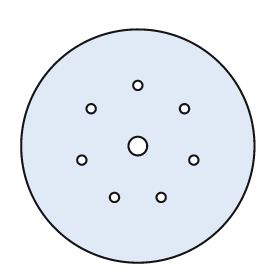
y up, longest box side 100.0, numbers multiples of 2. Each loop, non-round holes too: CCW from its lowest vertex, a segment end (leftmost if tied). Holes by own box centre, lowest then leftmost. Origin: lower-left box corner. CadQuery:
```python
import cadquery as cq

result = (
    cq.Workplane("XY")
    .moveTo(50.0, 50.0)
    .circle(50.0)
    .moveTo(40.0, 28.0)
    .circle(2.0)
    .moveTo(60.0, 28.0)
    .circle(2.0)
    .moveTo(26.0, 44.0)
    .circle(2.0)
    .moveTo(74.0, 44.0)
    .circle(2.0)
    .moveTo(50.0, 50.0)
    .circle(4.0)
    .moveTo(30.0, 66.0)
    .circle(2.0)
    .moveTo(70.0, 66.0)
    .circle(2.0)
    .moveTo(50.0, 76.0)
    .circle(2.0)
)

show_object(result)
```